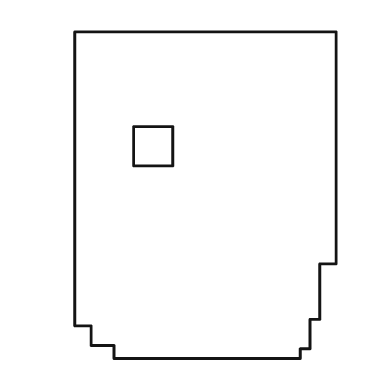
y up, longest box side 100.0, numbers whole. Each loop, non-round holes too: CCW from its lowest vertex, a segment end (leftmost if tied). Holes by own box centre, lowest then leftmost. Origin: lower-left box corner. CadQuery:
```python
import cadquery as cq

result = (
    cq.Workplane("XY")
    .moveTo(12.0, 0.0)
    .lineTo(69.0, 0.0)
    .lineTo(69.0, 3.0)
    .lineTo(72.0, 3.0)
    .lineTo(72.0, 12.0)
    .lineTo(75.0, 12.0)
    .lineTo(75.0, 29.0)
    .lineTo(80.0, 29.0)
    .lineTo(80.0, 100.0)
    .lineTo(0.0, 100.0)
    .lineTo(0.0, 10.0)
    .lineTo(5.0, 10.0)
    .lineTo(5.0, 4.0)
    .lineTo(12.0, 4.0)
    .close()
    .moveTo(18.0, 59.0)
    .lineTo(30.0, 59.0)
    .lineTo(30.0, 71.0)
    .lineTo(18.0, 71.0)
    .close()
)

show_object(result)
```